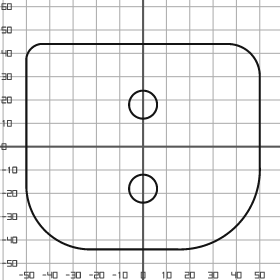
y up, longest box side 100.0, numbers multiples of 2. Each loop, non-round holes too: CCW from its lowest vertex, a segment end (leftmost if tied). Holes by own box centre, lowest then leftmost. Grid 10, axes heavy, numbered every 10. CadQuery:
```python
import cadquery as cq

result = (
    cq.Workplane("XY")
    .moveTo(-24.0, -44.0)
    .lineTo(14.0, -44.0)
    .threePointArc((40.0, -34.0), (50.0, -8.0))
    .lineTo(50.0, 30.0)
    .threePointArc((46.0, 40.0), (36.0, 44.0))
    .lineTo(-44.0, 44.0)
    .threePointArc((-48.0, 42.0), (-50.0, 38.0))
    .lineTo(-50.0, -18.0)
    .threePointArc((-42.0, -36.0), (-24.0, -44.0))
    .close()
    .moveTo(0.0, -18.0)
    .circle(6.0)
    .moveTo(0.0, 18.0)
    .circle(6.0)
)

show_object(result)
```